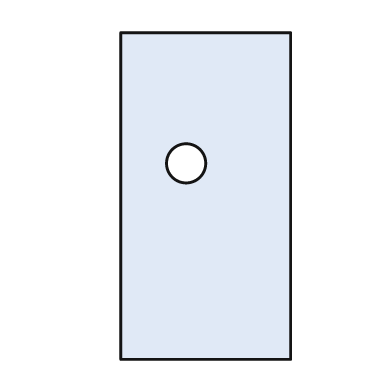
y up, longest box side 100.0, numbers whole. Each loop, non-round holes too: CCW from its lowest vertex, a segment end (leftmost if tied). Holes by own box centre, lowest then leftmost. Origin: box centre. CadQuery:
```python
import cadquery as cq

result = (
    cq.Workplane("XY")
    .moveTo(-26.0, -50.0)
    .lineTo(26.0, -50.0)
    .lineTo(26.0, 50.0)
    .lineTo(-26.0, 50.0)
    .close()
    .moveTo(-6.0, 10.0)
    .circle(6.0)
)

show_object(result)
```